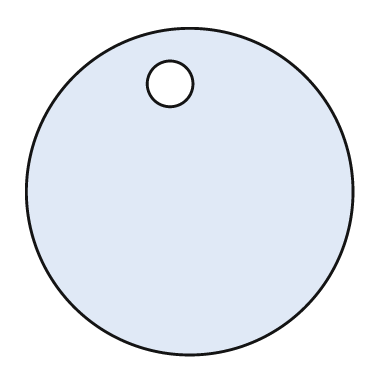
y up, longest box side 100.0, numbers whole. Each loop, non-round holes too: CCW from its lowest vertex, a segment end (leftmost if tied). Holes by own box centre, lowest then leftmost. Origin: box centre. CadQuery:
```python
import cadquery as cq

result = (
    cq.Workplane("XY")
    .moveTo(0.0, 0.0)
    .circle(50.0)
    .moveTo(-6.0, 33.0)
    .circle(7.0)
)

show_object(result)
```